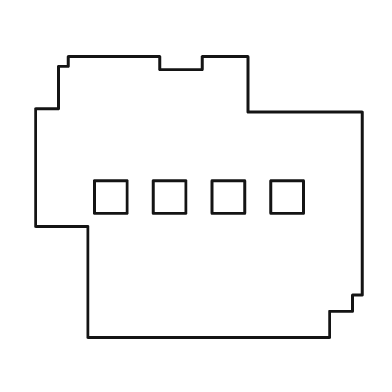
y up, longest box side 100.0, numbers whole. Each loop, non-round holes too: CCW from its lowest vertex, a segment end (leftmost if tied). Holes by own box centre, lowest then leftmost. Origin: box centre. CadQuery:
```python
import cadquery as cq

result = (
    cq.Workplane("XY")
    .moveTo(-34.0, -43.0)
    .lineTo(40.0, -43.0)
    .lineTo(40.0, -35.0)
    .lineTo(47.0, -35.0)
    .lineTo(47.0, -30.0)
    .lineTo(50.0, -30.0)
    .lineTo(50.0, 26.0)
    .lineTo(15.0, 26.0)
    .lineTo(15.0, 43.0)
    .lineTo(1.0, 43.0)
    .lineTo(1.0, 39.0)
    .lineTo(-12.0, 39.0)
    .lineTo(-12.0, 43.0)
    .lineTo(-40.0, 43.0)
    .lineTo(-40.0, 40.0)
    .lineTo(-43.0, 40.0)
    .lineTo(-43.0, 27.0)
    .lineTo(-50.0, 27.0)
    .lineTo(-50.0, -9.0)
    .lineTo(-34.0, -9.0)
    .close()
    .moveTo(-32.0, -5.0)
    .lineTo(-22.0, -5.0)
    .lineTo(-22.0, 5.0)
    .lineTo(-32.0, 5.0)
    .close()
    .moveTo(-14.0, -5.0)
    .lineTo(-4.0, -5.0)
    .lineTo(-4.0, 5.0)
    .lineTo(-14.0, 5.0)
    .close()
    .moveTo(4.0, -5.0)
    .lineTo(14.0, -5.0)
    .lineTo(14.0, 5.0)
    .lineTo(4.0, 5.0)
    .close()
    .moveTo(22.0, -5.0)
    .lineTo(32.0, -5.0)
    .lineTo(32.0, 5.0)
    .lineTo(22.0, 5.0)
    .close()
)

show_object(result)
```